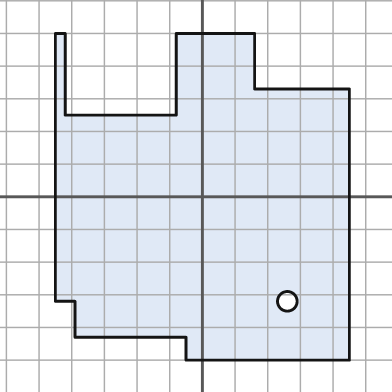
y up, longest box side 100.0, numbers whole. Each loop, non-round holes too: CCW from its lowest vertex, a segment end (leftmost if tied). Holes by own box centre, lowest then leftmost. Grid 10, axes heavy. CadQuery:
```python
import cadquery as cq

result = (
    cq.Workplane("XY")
    .moveTo(-5.0, -50.0)
    .lineTo(45.0, -50.0)
    .lineTo(45.0, 33.0)
    .lineTo(16.0, 33.0)
    .lineTo(16.0, 50.0)
    .lineTo(-8.0, 50.0)
    .lineTo(-8.0, 25.0)
    .lineTo(-42.0, 25.0)
    .lineTo(-42.0, 50.0)
    .lineTo(-45.0, 50.0)
    .lineTo(-45.0, -32.0)
    .lineTo(-39.0, -32.0)
    .lineTo(-39.0, -43.0)
    .lineTo(-5.0, -43.0)
    .close()
    .moveTo(26.0, -32.0)
    .circle(3.0)
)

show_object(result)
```